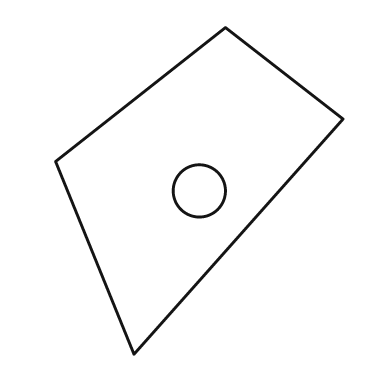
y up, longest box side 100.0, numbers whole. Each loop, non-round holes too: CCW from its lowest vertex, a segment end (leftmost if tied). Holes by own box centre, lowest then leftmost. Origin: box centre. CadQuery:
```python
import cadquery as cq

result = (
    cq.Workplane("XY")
    .moveTo(-20.0, -50.0)
    .lineTo(44.0, 22.0)
    .lineTo(8.0, 50.0)
    .lineTo(-44.0, 9.0)
    .close()
    .moveTo(0.0, 0.0)
    .circle(8.0)
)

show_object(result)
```